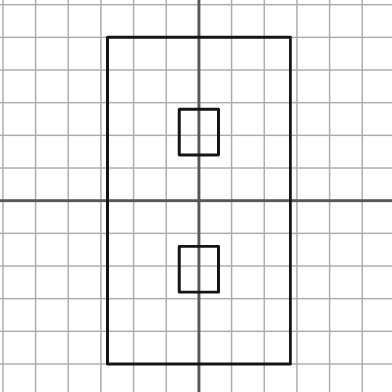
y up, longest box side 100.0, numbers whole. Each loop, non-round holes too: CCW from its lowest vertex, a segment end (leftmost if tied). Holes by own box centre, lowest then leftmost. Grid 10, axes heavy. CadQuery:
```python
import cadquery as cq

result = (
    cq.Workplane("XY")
    .moveTo(-28.0, -50.0)
    .lineTo(28.0, -50.0)
    .lineTo(28.0, 50.0)
    .lineTo(-28.0, 50.0)
    .close()
    .moveTo(-6.0, -28.0)
    .lineTo(6.0, -28.0)
    .lineTo(6.0, -14.0)
    .lineTo(-6.0, -14.0)
    .close()
    .moveTo(-6.0, 14.0)
    .lineTo(6.0, 14.0)
    .lineTo(6.0, 28.0)
    .lineTo(-6.0, 28.0)
    .close()
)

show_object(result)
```